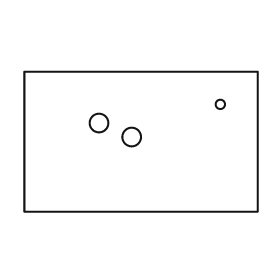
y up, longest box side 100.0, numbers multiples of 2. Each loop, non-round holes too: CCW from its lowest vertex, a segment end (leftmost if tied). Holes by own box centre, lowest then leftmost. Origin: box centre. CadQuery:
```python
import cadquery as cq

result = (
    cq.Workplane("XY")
    .moveTo(-50.0, -30.0)
    .lineTo(50.0, -30.0)
    .lineTo(50.0, 30.0)
    .lineTo(-50.0, 30.0)
    .close()
    .moveTo(-4.0, 2.0)
    .circle(4.0)
    .moveTo(-18.0, 8.0)
    .circle(4.0)
    .moveTo(34.0, 16.0)
    .circle(2.0)
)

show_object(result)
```